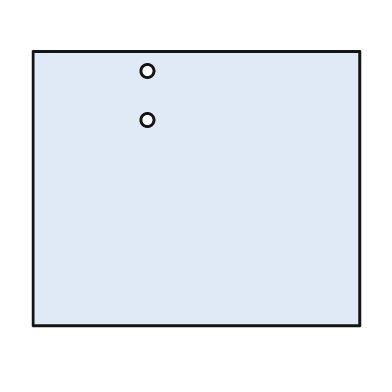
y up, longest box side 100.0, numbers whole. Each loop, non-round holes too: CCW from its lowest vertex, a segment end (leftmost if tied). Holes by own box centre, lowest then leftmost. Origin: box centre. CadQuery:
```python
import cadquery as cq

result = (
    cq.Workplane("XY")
    .moveTo(-50.0, -42.0)
    .lineTo(50.0, -42.0)
    .lineTo(50.0, 42.0)
    .lineTo(-50.0, 42.0)
    .close()
    .moveTo(-15.0, 21.0)
    .circle(2.0)
    .moveTo(-15.0, 36.0)
    .circle(2.0)
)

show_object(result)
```